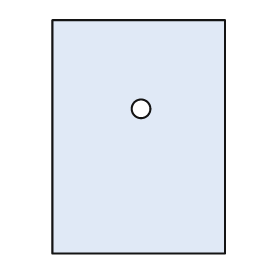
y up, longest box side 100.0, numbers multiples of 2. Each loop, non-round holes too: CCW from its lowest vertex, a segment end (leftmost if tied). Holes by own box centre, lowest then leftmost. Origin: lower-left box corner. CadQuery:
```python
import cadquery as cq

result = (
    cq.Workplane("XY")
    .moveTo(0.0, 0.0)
    .lineTo(74.0, 0.0)
    .lineTo(74.0, 100.0)
    .lineTo(0.0, 100.0)
    .close()
    .moveTo(38.0, 62.0)
    .circle(4.0)
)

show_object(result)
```